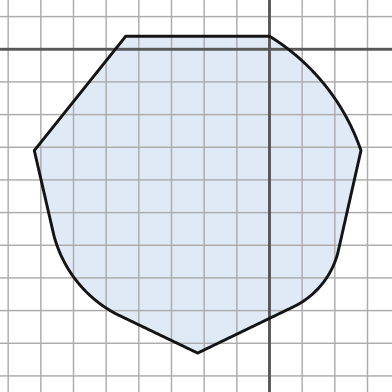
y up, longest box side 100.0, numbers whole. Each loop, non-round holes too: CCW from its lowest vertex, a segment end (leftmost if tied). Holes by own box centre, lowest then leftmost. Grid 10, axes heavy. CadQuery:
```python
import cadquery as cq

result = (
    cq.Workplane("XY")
    .moveTo(-22.0, -93.0)
    .lineTo(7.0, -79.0)
    .threePointArc((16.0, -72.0), (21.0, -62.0))
    .lineTo(28.0, -31.0)
    .threePointArc((17.0, -11.0), (0.0, 4.0))
    .lineTo(-44.0, 4.0)
    .lineTo(-72.0, -31.0)
    .lineTo(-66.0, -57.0)
    .threePointArc((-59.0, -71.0), (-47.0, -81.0))
    .close()
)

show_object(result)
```